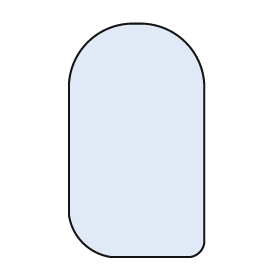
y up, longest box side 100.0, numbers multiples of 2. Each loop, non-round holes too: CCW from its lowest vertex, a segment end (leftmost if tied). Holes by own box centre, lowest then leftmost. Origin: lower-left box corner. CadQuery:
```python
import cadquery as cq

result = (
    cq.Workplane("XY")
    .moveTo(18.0, 0.0)
    .lineTo(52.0, 0.0)
    .threePointArc((56.0, 2.0), (58.0, 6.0))
    .lineTo(58.0, 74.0)
    .threePointArc((50.0, 92.0), (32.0, 100.0))
    .lineTo(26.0, 100.0)
    .threePointArc((8.0, 92.0), (0.0, 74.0))
    .lineTo(0.0, 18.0)
    .threePointArc((6.0, 6.0), (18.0, 0.0))
    .close()
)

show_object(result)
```